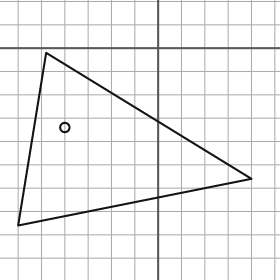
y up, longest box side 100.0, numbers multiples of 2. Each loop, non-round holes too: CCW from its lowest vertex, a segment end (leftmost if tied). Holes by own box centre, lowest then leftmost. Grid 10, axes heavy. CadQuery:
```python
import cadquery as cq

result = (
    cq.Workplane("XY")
    .moveTo(-60.0, -76.0)
    .lineTo(40.0, -56.0)
    .lineTo(-48.0, -2.0)
    .close()
    .moveTo(-40.0, -34.0)
    .circle(2.0)
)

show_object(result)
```